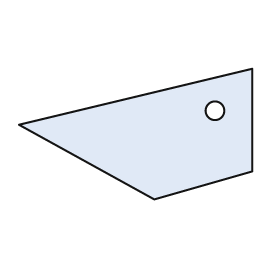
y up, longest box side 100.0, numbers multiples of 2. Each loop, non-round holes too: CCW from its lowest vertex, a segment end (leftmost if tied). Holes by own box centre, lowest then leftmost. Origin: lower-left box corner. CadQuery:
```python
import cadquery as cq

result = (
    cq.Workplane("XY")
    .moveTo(58.0, 0.0)
    .lineTo(100.0, 12.0)
    .lineTo(100.0, 56.0)
    .lineTo(0.0, 32.0)
    .close()
    .moveTo(84.0, 38.0)
    .circle(4.0)
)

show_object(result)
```